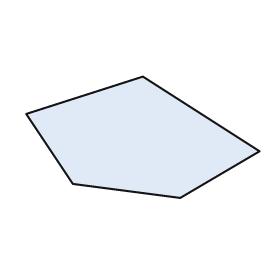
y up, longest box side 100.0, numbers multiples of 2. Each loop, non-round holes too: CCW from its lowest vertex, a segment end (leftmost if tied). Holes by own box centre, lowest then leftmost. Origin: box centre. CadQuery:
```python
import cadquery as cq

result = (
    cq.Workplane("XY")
    .moveTo(16.0, -26.0)
    .lineTo(50.0, -6.0)
    .lineTo(0.0, 26.0)
    .lineTo(-50.0, 10.0)
    .lineTo(-30.0, -20.0)
    .close()
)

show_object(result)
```